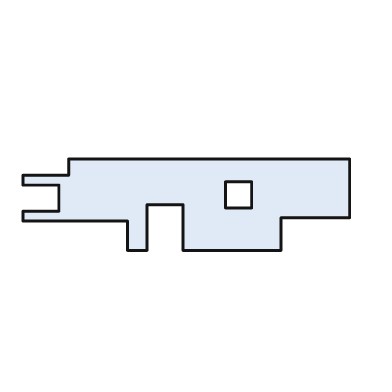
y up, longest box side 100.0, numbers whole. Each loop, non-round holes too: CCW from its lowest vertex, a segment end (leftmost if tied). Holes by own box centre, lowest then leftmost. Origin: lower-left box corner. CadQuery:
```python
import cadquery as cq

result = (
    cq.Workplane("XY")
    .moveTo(32.0, 0.0)
    .lineTo(38.0, 0.0)
    .lineTo(38.0, 14.0)
    .lineTo(49.0, 14.0)
    .lineTo(49.0, 0.0)
    .lineTo(79.0, 0.0)
    .lineTo(79.0, 10.0)
    .lineTo(100.0, 10.0)
    .lineTo(100.0, 28.0)
    .lineTo(14.0, 28.0)
    .lineTo(14.0, 23.0)
    .lineTo(0.0, 23.0)
    .lineTo(0.0, 20.0)
    .lineTo(11.0, 20.0)
    .lineTo(11.0, 12.0)
    .lineTo(0.0, 12.0)
    .lineTo(0.0, 9.0)
    .lineTo(32.0, 9.0)
    .close()
    .moveTo(62.0, 13.0)
    .lineTo(70.0, 13.0)
    .lineTo(70.0, 21.0)
    .lineTo(62.0, 21.0)
    .close()
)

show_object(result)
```